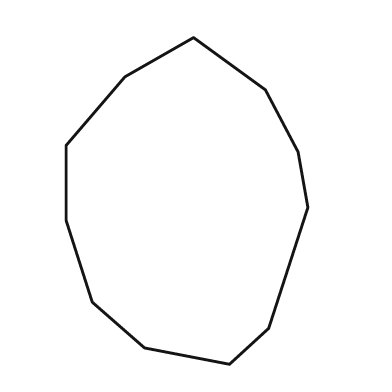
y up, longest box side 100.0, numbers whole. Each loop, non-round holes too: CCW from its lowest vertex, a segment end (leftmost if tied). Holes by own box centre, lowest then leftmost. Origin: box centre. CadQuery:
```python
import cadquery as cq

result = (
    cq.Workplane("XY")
    .moveTo(13.0, -50.0)
    .lineTo(25.0, -39.0)
    .lineTo(37.0, -2.0)
    .lineTo(34.0, 15.0)
    .lineTo(24.0, 34.0)
    .lineTo(2.0, 50.0)
    .lineTo(-19.0, 38.0)
    .lineTo(-37.0, 17.0)
    .lineTo(-37.0, -6.0)
    .lineTo(-29.0, -31.0)
    .lineTo(-13.0, -45.0)
    .close()
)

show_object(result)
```